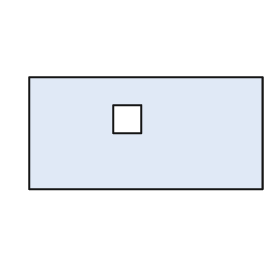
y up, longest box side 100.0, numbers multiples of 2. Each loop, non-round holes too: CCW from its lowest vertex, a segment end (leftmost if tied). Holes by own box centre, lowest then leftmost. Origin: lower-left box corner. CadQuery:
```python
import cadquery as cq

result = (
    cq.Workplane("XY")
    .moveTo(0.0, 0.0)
    .lineTo(100.0, 0.0)
    .lineTo(100.0, 48.0)
    .lineTo(0.0, 48.0)
    .close()
    .moveTo(36.0, 24.0)
    .lineTo(48.0, 24.0)
    .lineTo(48.0, 36.0)
    .lineTo(36.0, 36.0)
    .close()
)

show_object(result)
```